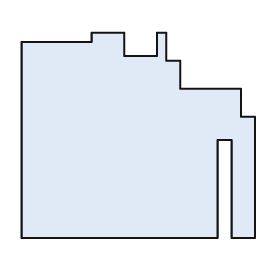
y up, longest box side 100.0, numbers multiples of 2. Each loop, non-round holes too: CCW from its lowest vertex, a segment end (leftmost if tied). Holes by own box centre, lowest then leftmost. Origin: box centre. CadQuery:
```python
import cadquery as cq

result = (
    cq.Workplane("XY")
    .moveTo(-50.0, -44.0)
    .lineTo(34.0, -44.0)
    .lineTo(34.0, -2.0)
    .lineTo(40.0, -2.0)
    .lineTo(40.0, -44.0)
    .lineTo(50.0, -44.0)
    .lineTo(50.0, 8.0)
    .lineTo(44.0, 8.0)
    .lineTo(44.0, 20.0)
    .lineTo(18.0, 20.0)
    .lineTo(18.0, 32.0)
    .lineTo(12.0, 32.0)
    .lineTo(12.0, 44.0)
    .lineTo(8.0, 44.0)
    .lineTo(8.0, 34.0)
    .lineTo(-6.0, 34.0)
    .lineTo(-6.0, 44.0)
    .lineTo(-20.0, 44.0)
    .lineTo(-20.0, 40.0)
    .lineTo(-50.0, 40.0)
    .close()
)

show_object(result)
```